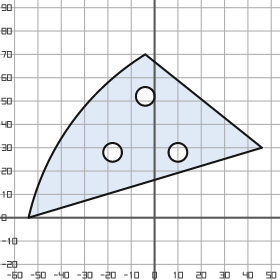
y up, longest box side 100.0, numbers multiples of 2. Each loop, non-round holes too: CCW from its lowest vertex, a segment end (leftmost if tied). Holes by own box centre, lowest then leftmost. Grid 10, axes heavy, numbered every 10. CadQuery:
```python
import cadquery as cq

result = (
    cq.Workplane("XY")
    .moveTo(-54.0, 0.0)
    .lineTo(46.0, 30.0)
    .lineTo(-4.0, 70.0)
    .threePointArc((-36.0, 40.0), (-54.0, 0.0))
    .close()
    .moveTo(-18.0, 28.0)
    .circle(4.0)
    .moveTo(10.0, 28.0)
    .circle(4.0)
    .moveTo(-4.0, 52.0)
    .circle(4.0)
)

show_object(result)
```